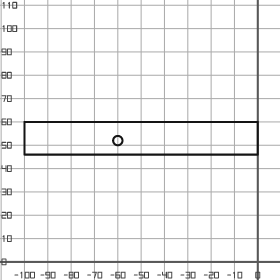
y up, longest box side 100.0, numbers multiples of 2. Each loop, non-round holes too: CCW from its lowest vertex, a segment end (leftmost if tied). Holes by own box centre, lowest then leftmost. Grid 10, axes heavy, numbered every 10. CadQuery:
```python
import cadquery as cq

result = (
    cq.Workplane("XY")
    .moveTo(-100.0, 46.0)
    .lineTo(0.0, 46.0)
    .lineTo(0.0, 60.0)
    .lineTo(-100.0, 60.0)
    .close()
    .moveTo(-60.0, 52.0)
    .circle(2.0)
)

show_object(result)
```